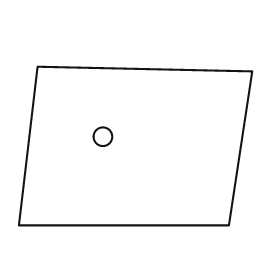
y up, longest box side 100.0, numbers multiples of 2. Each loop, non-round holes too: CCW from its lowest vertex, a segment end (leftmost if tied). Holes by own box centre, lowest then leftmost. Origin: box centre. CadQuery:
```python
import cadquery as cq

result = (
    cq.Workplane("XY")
    .moveTo(-50.0, -34.0)
    .lineTo(40.0, -34.0)
    .lineTo(50.0, 32.0)
    .lineTo(-42.0, 34.0)
    .close()
    .moveTo(-14.0, 4.0)
    .circle(4.0)
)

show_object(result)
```